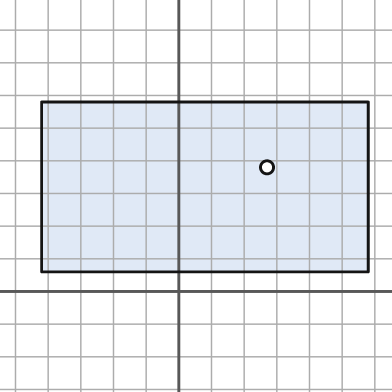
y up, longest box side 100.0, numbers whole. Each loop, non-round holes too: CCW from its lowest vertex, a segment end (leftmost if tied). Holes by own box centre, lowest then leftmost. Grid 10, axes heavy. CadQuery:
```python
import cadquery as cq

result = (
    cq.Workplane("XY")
    .moveTo(-42.0, 6.0)
    .lineTo(58.0, 6.0)
    .lineTo(58.0, 58.0)
    .lineTo(-42.0, 58.0)
    .close()
    .moveTo(27.0, 38.0)
    .circle(2.0)
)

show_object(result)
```